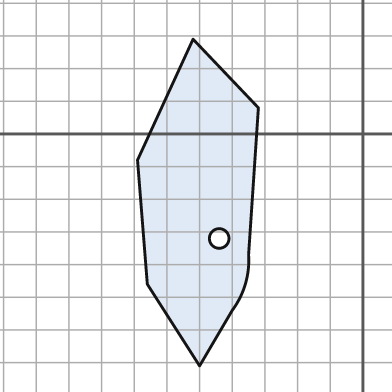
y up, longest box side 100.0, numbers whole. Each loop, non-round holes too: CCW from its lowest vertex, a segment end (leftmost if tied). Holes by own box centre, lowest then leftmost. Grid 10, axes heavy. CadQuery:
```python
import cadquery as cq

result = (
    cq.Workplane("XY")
    .moveTo(-50.0, -71.0)
    .lineTo(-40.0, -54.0)
    .threePointArc((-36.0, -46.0), (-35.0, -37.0))
    .lineTo(-32.0, 8.0)
    .lineTo(-52.0, 29.0)
    .lineTo(-69.0, -8.0)
    .lineTo(-66.0, -46.0)
    .close()
    .moveTo(-44.0, -32.0)
    .circle(3.0)
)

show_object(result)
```